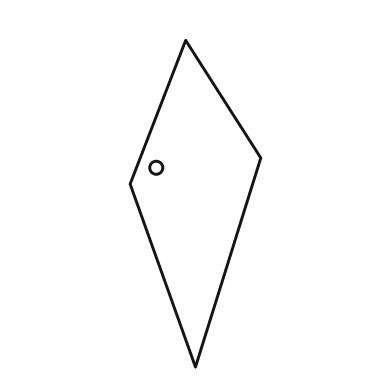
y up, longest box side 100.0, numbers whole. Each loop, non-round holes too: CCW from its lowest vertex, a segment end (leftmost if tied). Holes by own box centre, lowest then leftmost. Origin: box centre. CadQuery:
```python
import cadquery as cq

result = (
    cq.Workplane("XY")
    .moveTo(0.0, -50.0)
    .lineTo(20.0, 14.0)
    .lineTo(-3.0, 50.0)
    .lineTo(-20.0, 6.0)
    .close()
    .moveTo(-12.0, 11.0)
    .circle(2.0)
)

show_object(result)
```